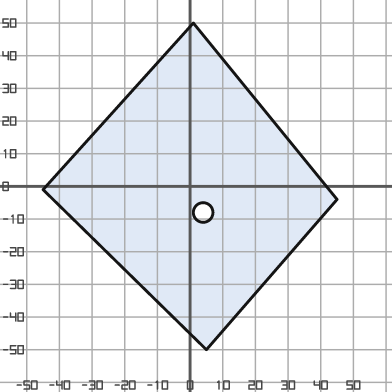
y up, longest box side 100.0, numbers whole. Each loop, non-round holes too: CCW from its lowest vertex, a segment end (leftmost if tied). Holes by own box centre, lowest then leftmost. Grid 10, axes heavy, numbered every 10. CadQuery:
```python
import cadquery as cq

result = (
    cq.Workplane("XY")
    .moveTo(5.0, -50.0)
    .lineTo(45.0, -4.0)
    .lineTo(1.0, 50.0)
    .lineTo(-45.0, -1.0)
    .close()
    .moveTo(4.0, -8.0)
    .circle(3.0)
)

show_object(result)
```